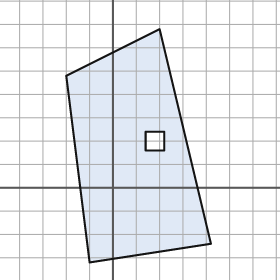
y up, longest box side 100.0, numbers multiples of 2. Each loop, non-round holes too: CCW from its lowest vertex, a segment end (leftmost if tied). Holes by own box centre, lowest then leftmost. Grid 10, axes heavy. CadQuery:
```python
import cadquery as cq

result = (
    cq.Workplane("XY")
    .moveTo(-10.0, -32.0)
    .lineTo(42.0, -24.0)
    .lineTo(20.0, 68.0)
    .lineTo(-20.0, 48.0)
    .close()
    .moveTo(14.0, 16.0)
    .lineTo(22.0, 16.0)
    .lineTo(22.0, 24.0)
    .lineTo(14.0, 24.0)
    .close()
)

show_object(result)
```